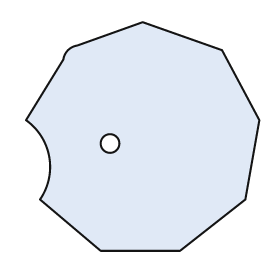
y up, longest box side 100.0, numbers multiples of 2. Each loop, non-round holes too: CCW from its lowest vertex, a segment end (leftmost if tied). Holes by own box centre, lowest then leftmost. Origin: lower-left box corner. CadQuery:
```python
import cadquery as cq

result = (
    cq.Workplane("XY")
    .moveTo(32.0, 0.0)
    .lineTo(66.0, 0.0)
    .lineTo(94.0, 22.0)
    .lineTo(100.0, 56.0)
    .lineTo(84.0, 86.0)
    .lineTo(50.0, 98.0)
    .lineTo(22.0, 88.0)
    .threePointArc((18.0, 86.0), (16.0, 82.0))
    .lineTo(0.0, 56.0)
    .threePointArc((10.0, 40.0), (6.0, 22.0))
    .close()
    .moveTo(36.0, 46.0)
    .circle(4.0)
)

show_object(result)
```